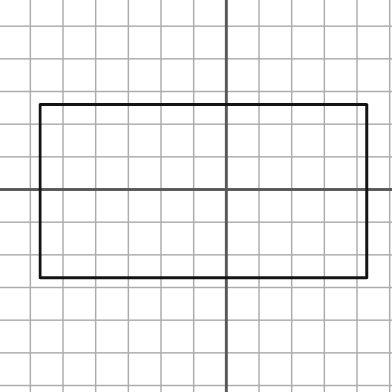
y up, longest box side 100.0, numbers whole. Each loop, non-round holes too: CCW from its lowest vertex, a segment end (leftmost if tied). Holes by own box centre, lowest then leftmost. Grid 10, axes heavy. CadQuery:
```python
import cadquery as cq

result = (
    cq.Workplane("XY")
    .moveTo(-57.0, -27.0)
    .lineTo(43.0, -27.0)
    .lineTo(43.0, 26.0)
    .lineTo(-57.0, 26.0)
    .close()
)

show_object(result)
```